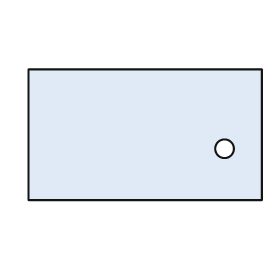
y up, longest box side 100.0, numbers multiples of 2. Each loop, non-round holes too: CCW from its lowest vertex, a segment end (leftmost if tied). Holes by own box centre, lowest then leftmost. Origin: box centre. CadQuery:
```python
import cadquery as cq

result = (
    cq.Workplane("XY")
    .moveTo(-50.0, -28.0)
    .lineTo(50.0, -28.0)
    .lineTo(50.0, 28.0)
    .lineTo(-50.0, 28.0)
    .close()
    .moveTo(34.0, -6.0)
    .circle(4.0)
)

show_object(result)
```